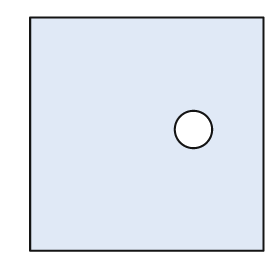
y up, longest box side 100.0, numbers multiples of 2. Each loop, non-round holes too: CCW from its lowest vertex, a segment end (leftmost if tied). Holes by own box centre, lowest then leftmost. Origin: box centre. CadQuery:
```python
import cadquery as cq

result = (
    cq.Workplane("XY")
    .moveTo(-50.0, -50.0)
    .lineTo(50.0, -50.0)
    .lineTo(50.0, 50.0)
    .lineTo(-50.0, 50.0)
    .close()
    .moveTo(20.0, 2.0)
    .circle(8.0)
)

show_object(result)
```